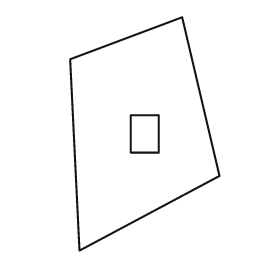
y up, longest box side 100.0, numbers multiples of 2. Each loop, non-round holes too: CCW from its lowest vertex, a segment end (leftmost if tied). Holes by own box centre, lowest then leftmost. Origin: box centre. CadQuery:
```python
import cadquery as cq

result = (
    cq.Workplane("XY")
    .moveTo(-28.0, -50.0)
    .lineTo(32.0, -18.0)
    .lineTo(16.0, 50.0)
    .lineTo(-32.0, 32.0)
    .close()
    .moveTo(-6.0, -8.0)
    .lineTo(6.0, -8.0)
    .lineTo(6.0, 8.0)
    .lineTo(-6.0, 8.0)
    .close()
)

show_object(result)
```